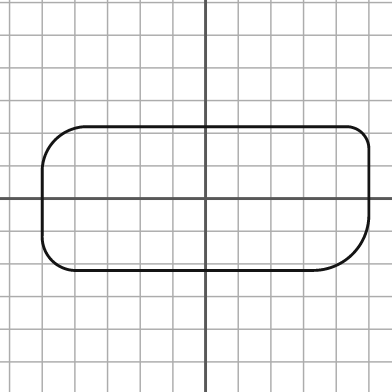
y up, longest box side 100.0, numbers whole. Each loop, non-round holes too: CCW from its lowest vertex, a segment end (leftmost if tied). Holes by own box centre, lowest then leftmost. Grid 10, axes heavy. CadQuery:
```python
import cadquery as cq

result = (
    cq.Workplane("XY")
    .moveTo(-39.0, -22.0)
    .lineTo(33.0, -22.0)
    .threePointArc((45.0, -17.0), (50.0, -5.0))
    .lineTo(50.0, 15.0)
    .threePointArc((48.0, 20.0), (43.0, 22.0))
    .lineTo(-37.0, 22.0)
    .threePointArc((-46.0, 18.0), (-50.0, 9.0))
    .lineTo(-50.0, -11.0)
    .threePointArc((-47.0, -19.0), (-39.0, -22.0))
    .close()
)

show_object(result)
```